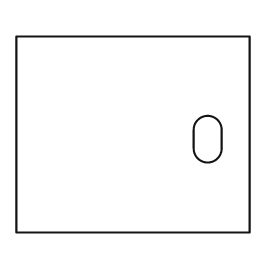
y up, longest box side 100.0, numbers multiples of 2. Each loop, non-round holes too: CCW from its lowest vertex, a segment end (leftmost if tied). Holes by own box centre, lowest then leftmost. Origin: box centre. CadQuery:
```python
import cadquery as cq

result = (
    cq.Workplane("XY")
    .moveTo(-50.0, -42.0)
    .lineTo(50.0, -42.0)
    .lineTo(50.0, 42.0)
    .lineTo(-50.0, 42.0)
    .close()
    .moveTo(26.0, -6.0)
    .threePointArc((32.0, -12.0), (38.0, -6.0))
    .lineTo(38.0, 2.0)
    .threePointArc((32.0, 8.0), (26.0, 2.0))
    .close()
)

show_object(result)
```